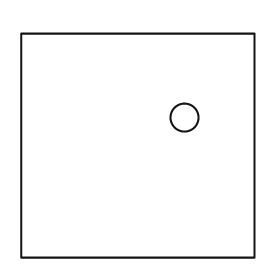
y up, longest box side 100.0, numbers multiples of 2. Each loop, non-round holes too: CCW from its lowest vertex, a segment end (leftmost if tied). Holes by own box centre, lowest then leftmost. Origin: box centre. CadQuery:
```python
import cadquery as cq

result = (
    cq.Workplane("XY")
    .moveTo(-50.0, -48.0)
    .lineTo(50.0, -48.0)
    .lineTo(50.0, 48.0)
    .lineTo(-50.0, 48.0)
    .close()
    .moveTo(20.0, 12.0)
    .circle(6.0)
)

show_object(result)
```